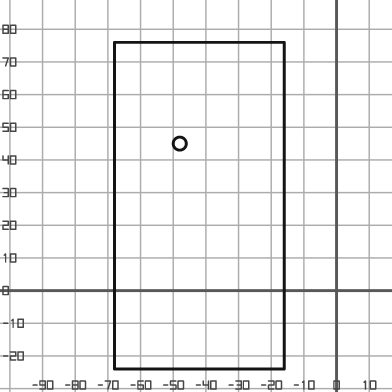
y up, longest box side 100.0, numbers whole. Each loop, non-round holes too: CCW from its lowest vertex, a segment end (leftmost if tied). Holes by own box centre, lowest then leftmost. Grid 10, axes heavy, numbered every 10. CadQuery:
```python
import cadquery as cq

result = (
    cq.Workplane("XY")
    .moveTo(-68.0, -24.0)
    .lineTo(-16.0, -24.0)
    .lineTo(-16.0, 76.0)
    .lineTo(-68.0, 76.0)
    .close()
    .moveTo(-48.0, 45.0)
    .circle(2.0)
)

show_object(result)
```